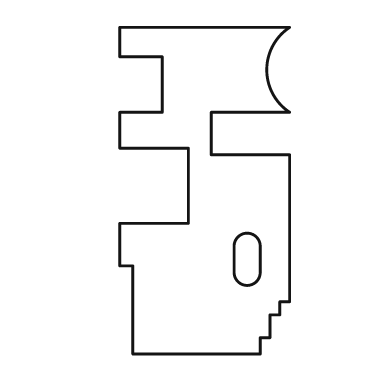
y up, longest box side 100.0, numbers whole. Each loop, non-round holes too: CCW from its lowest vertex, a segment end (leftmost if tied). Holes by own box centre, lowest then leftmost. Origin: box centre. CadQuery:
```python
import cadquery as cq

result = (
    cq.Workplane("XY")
    .moveTo(-22.0, -50.0)
    .lineTo(17.0, -50.0)
    .lineTo(17.0, -45.0)
    .lineTo(20.0, -45.0)
    .lineTo(20.0, -38.0)
    .lineTo(23.0, -38.0)
    .lineTo(23.0, -34.0)
    .lineTo(26.0, -34.0)
    .lineTo(26.0, 11.0)
    .lineTo(2.0, 11.0)
    .lineTo(2.0, 24.0)
    .lineTo(26.0, 24.0)
    .threePointArc((19.0, 37.0), (26.0, 50.0))
    .lineTo(-26.0, 50.0)
    .lineTo(-26.0, 41.0)
    .lineTo(-13.0, 41.0)
    .lineTo(-13.0, 24.0)
    .lineTo(-26.0, 24.0)
    .lineTo(-26.0, 13.0)
    .lineTo(-5.0, 13.0)
    .lineTo(-5.0, -10.0)
    .lineTo(-26.0, -10.0)
    .lineTo(-26.0, -23.0)
    .lineTo(-22.0, -23.0)
    .close()
    .moveTo(9.0, -25.0)
    .threePointArc((13.0, -29.0), (17.0, -25.0))
    .lineTo(17.0, -17.0)
    .threePointArc((13.0, -13.0), (9.0, -17.0))
    .close()
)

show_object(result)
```